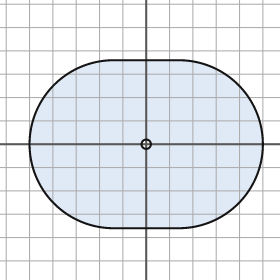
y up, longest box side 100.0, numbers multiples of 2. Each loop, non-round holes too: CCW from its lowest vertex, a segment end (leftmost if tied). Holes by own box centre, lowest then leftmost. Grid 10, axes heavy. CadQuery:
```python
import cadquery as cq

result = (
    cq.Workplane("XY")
    .moveTo(-14.0, -36.0)
    .lineTo(14.0, -36.0)
    .threePointArc((50.0, 0.0), (14.0, 36.0))
    .lineTo(-14.0, 36.0)
    .threePointArc((-50.0, 0.0), (-14.0, -36.0))
    .close()
    .moveTo(0.0, 0.0)
    .circle(2.0)
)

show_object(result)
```